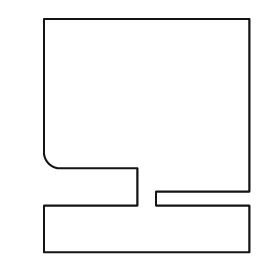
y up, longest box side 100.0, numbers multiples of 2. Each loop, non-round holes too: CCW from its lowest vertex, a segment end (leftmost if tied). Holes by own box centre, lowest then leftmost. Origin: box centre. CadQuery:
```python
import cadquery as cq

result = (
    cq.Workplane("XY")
    .moveTo(-44.0, -50.0)
    .lineTo(44.0, -50.0)
    .lineTo(44.0, -30.0)
    .lineTo(4.0, -30.0)
    .lineTo(4.0, -24.0)
    .lineTo(44.0, -24.0)
    .lineTo(44.0, 50.0)
    .lineTo(-44.0, 50.0)
    .lineTo(-44.0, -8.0)
    .threePointArc((-42.0, -12.0), (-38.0, -14.0))
    .lineTo(-4.0, -14.0)
    .lineTo(-4.0, -30.0)
    .lineTo(-44.0, -30.0)
    .close()
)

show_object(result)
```